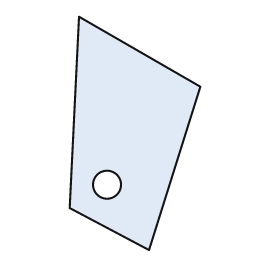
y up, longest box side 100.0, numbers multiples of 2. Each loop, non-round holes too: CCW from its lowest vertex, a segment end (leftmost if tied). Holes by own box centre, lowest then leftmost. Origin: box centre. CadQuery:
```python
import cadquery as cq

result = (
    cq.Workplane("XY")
    .moveTo(6.0, -50.0)
    .lineTo(28.0, 20.0)
    .lineTo(-24.0, 50.0)
    .lineTo(-28.0, -32.0)
    .close()
    .moveTo(-12.0, -22.0)
    .circle(6.0)
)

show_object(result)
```